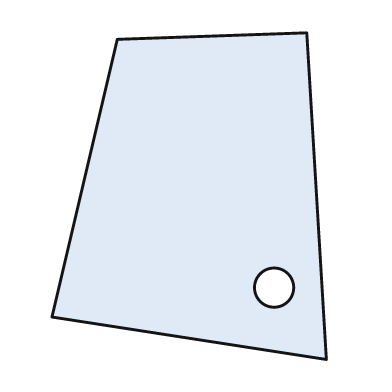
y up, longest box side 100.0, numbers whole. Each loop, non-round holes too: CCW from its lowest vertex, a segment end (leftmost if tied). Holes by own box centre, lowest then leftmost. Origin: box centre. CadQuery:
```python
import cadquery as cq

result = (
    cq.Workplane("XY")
    .moveTo(42.0, -50.0)
    .lineTo(36.0, 50.0)
    .lineTo(-22.0, 48.0)
    .lineTo(-42.0, -37.0)
    .close()
    .moveTo(26.0, -28.0)
    .circle(6.0)
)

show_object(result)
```